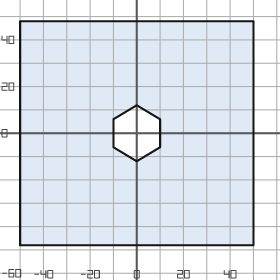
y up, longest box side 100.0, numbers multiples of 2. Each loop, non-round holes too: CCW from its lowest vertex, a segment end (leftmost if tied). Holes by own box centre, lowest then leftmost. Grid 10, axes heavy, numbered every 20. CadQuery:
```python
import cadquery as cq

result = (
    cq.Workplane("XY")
    .moveTo(-50.0, -48.0)
    .lineTo(50.0, -48.0)
    .lineTo(50.0, 48.0)
    .lineTo(-50.0, 48.0)
    .close()
    .moveTo(0.0, -12.0)
    .lineTo(10.0, -6.0)
    .lineTo(10.0, 6.0)
    .lineTo(0.0, 12.0)
    .lineTo(-10.0, 6.0)
    .lineTo(-10.0, -6.0)
    .close()
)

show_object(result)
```